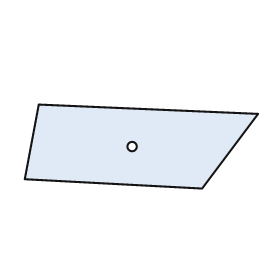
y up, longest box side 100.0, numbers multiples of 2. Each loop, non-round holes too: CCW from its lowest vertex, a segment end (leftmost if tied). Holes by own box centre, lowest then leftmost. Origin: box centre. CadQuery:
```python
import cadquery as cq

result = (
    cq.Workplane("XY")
    .moveTo(26.0, -18.0)
    .lineTo(50.0, 14.0)
    .lineTo(-44.0, 18.0)
    .lineTo(-50.0, -14.0)
    .close()
    .moveTo(-4.0, 0.0)
    .circle(2.0)
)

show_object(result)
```